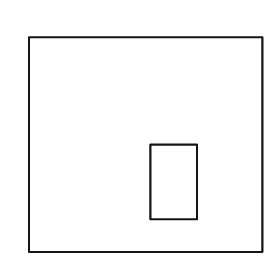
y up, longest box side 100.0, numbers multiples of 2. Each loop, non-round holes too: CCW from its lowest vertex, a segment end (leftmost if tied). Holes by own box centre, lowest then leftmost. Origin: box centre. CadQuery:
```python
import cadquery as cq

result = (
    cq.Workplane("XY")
    .moveTo(-50.0, -46.0)
    .lineTo(50.0, -46.0)
    .lineTo(50.0, 46.0)
    .lineTo(-50.0, 46.0)
    .close()
    .moveTo(2.0, -32.0)
    .lineTo(22.0, -32.0)
    .lineTo(22.0, 0.0)
    .lineTo(2.0, 0.0)
    .close()
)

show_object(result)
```